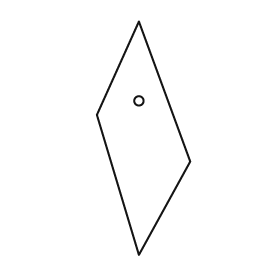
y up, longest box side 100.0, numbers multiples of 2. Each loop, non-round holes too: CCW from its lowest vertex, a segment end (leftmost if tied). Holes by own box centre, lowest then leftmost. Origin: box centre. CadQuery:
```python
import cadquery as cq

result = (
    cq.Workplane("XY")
    .moveTo(-2.0, -50.0)
    .lineTo(20.0, -10.0)
    .lineTo(-2.0, 50.0)
    .lineTo(-20.0, 10.0)
    .close()
    .moveTo(-2.0, 16.0)
    .circle(2.0)
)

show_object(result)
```